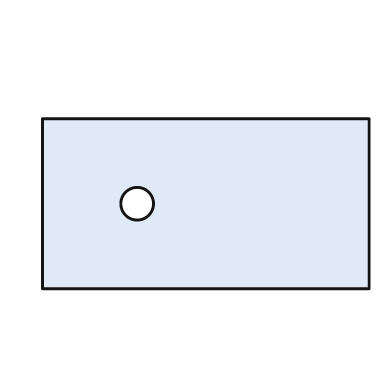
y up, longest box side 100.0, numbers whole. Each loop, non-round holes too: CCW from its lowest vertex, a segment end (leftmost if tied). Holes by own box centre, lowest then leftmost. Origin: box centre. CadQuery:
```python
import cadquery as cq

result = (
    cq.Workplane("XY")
    .moveTo(-50.0, -26.0)
    .lineTo(50.0, -26.0)
    .lineTo(50.0, 26.0)
    .lineTo(-50.0, 26.0)
    .close()
    .moveTo(-21.0, 0.0)
    .circle(5.0)
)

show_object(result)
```